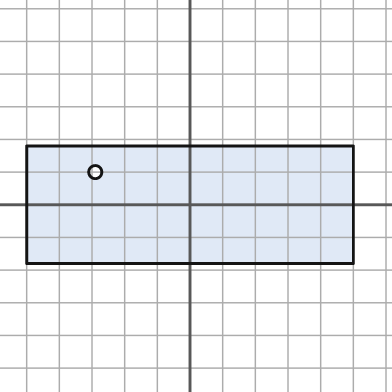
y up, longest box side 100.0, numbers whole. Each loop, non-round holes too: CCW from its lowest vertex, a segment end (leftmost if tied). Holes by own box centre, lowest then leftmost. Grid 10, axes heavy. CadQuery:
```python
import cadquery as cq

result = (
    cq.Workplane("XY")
    .moveTo(-50.0, -18.0)
    .lineTo(50.0, -18.0)
    .lineTo(50.0, 18.0)
    .lineTo(-50.0, 18.0)
    .close()
    .moveTo(-29.0, 10.0)
    .circle(2.0)
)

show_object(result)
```